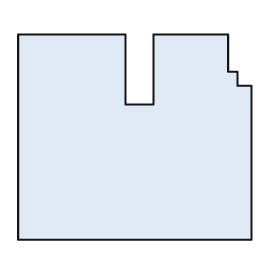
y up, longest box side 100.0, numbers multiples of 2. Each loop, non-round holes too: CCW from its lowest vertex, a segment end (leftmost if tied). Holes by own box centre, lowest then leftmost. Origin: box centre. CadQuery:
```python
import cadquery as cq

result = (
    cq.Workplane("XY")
    .moveTo(-50.0, -44.0)
    .lineTo(50.0, -44.0)
    .lineTo(50.0, 22.0)
    .lineTo(44.0, 22.0)
    .lineTo(44.0, 28.0)
    .lineTo(40.0, 28.0)
    .lineTo(40.0, 44.0)
    .lineTo(8.0, 44.0)
    .lineTo(8.0, 14.0)
    .lineTo(-4.0, 14.0)
    .lineTo(-4.0, 44.0)
    .lineTo(-50.0, 44.0)
    .close()
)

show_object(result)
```